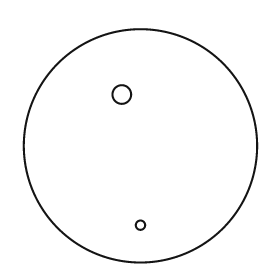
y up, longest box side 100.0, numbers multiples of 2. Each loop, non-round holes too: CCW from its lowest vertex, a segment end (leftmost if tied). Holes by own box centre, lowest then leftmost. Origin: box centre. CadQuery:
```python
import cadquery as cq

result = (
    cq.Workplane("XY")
    .moveTo(0.0, 0.0)
    .circle(50.0)
    .moveTo(0.0, -34.0)
    .circle(2.0)
    .moveTo(-8.0, 22.0)
    .circle(4.0)
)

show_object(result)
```